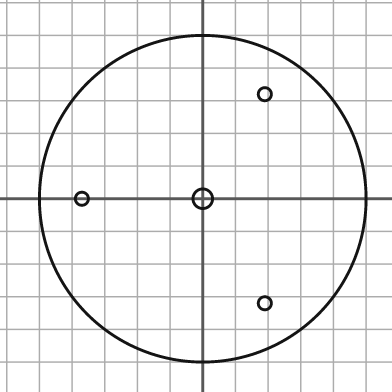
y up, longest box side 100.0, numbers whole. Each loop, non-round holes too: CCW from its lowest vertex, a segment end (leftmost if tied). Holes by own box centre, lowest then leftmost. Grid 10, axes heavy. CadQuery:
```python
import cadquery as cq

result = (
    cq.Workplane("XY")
    .moveTo(0.0, 0.0)
    .circle(50.0)
    .moveTo(19.0, -32.0)
    .circle(2.0)
    .moveTo(-37.0, 0.0)
    .circle(2.0)
    .moveTo(0.0, 0.0)
    .circle(3.0)
    .moveTo(19.0, 32.0)
    .circle(2.0)
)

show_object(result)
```